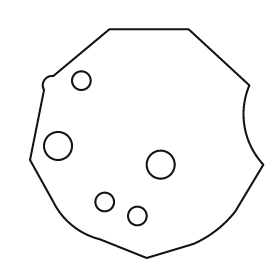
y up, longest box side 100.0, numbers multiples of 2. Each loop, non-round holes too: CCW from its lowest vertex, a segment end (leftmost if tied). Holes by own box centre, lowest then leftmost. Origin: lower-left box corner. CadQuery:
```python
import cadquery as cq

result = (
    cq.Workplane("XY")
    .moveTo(50.0, 0.0)
    .lineTo(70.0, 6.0)
    .threePointArc((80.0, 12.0), (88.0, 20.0))
    .lineTo(100.0, 40.0)
    .threePointArc((92.0, 56.0), (94.0, 74.0))
    .lineTo(68.0, 98.0)
    .lineTo(34.0, 98.0)
    .lineTo(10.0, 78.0)
    .threePointArc((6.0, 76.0), (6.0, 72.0))
    .lineTo(0.0, 42.0)
    .lineTo(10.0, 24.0)
    .threePointArc((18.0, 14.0), (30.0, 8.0))
    .close()
    .moveTo(46.0, 18.0)
    .circle(4.0)
    .moveTo(32.0, 24.0)
    .circle(4.0)
    .moveTo(56.0, 40.0)
    .circle(6.0)
    .moveTo(12.0, 48.0)
    .circle(6.0)
    .moveTo(22.0, 76.0)
    .circle(4.0)
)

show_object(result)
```